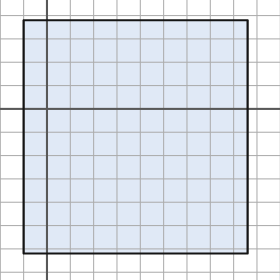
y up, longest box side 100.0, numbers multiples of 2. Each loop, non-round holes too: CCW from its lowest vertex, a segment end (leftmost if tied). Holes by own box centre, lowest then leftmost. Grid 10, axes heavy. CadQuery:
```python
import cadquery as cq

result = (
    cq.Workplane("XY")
    .moveTo(-10.0, -62.0)
    .lineTo(86.0, -62.0)
    .lineTo(86.0, 38.0)
    .lineTo(-10.0, 38.0)
    .close()
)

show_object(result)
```